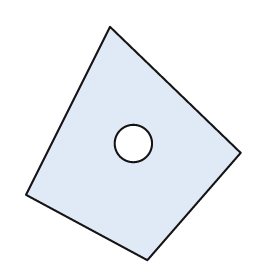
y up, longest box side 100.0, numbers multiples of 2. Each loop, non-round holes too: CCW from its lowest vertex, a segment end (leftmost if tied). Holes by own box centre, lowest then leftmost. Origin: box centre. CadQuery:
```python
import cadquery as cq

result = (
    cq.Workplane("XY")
    .moveTo(6.0, -50.0)
    .lineTo(46.0, -4.0)
    .lineTo(-10.0, 50.0)
    .lineTo(-46.0, -22.0)
    .close()
    .moveTo(0.0, 0.0)
    .circle(8.0)
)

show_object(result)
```